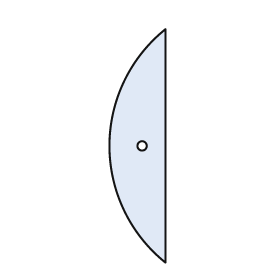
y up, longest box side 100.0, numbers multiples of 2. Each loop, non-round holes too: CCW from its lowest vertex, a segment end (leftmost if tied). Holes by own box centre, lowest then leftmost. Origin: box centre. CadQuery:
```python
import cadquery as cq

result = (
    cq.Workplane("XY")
    .moveTo(12.0, -50.0)
    .lineTo(12.0, 50.0)
    .threePointArc((-12.0, 0.0), (12.0, -50.0))
    .close()
    .moveTo(2.0, 0.0)
    .circle(2.0)
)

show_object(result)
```